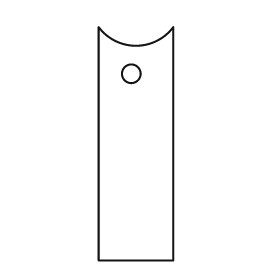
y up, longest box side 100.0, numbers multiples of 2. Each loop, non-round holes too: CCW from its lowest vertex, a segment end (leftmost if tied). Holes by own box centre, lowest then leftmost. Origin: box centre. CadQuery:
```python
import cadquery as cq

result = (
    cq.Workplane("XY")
    .moveTo(-16.0, -50.0)
    .lineTo(16.0, -50.0)
    .lineTo(16.0, 50.0)
    .threePointArc((0.0, 42.0), (-16.0, 50.0))
    .close()
    .moveTo(-2.0, 30.0)
    .circle(4.0)
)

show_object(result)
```